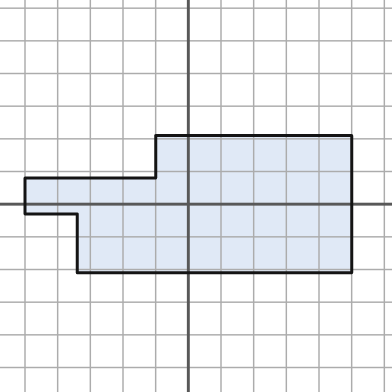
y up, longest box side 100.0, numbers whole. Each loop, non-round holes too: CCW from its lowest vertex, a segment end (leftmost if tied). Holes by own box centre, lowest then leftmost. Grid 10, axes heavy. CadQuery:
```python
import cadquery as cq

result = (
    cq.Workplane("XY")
    .moveTo(-34.0, -21.0)
    .lineTo(50.0, -21.0)
    .lineTo(50.0, 21.0)
    .lineTo(-10.0, 21.0)
    .lineTo(-10.0, 8.0)
    .lineTo(-50.0, 8.0)
    .lineTo(-50.0, -3.0)
    .lineTo(-34.0, -3.0)
    .close()
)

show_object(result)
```